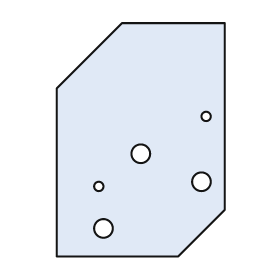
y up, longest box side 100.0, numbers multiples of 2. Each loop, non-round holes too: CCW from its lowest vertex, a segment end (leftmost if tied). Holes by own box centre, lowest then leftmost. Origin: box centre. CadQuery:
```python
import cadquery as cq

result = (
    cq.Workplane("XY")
    .moveTo(-36.0, -50.0)
    .lineTo(16.0, -50.0)
    .lineTo(36.0, -30.0)
    .lineTo(36.0, 50.0)
    .lineTo(-8.0, 50.0)
    .lineTo(-36.0, 22.0)
    .close()
    .moveTo(-16.0, -38.0)
    .circle(4.0)
    .moveTo(-18.0, -20.0)
    .circle(2.0)
    .moveTo(26.0, -18.0)
    .circle(4.0)
    .moveTo(0.0, -6.0)
    .circle(4.0)
    .moveTo(28.0, 10.0)
    .circle(2.0)
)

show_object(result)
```